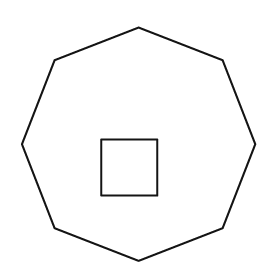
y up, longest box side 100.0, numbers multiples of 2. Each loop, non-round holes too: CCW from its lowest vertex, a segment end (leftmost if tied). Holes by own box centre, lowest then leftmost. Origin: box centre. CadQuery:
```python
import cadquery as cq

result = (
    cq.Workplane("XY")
    .moveTo(0.0, -50.0)
    .lineTo(36.0, -36.0)
    .lineTo(50.0, 0.0)
    .lineTo(36.0, 36.0)
    .lineTo(0.0, 50.0)
    .lineTo(-36.0, 36.0)
    .lineTo(-50.0, 0.0)
    .lineTo(-36.0, -36.0)
    .close()
    .moveTo(-16.0, -22.0)
    .lineTo(8.0, -22.0)
    .lineTo(8.0, 2.0)
    .lineTo(-16.0, 2.0)
    .close()
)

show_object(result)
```